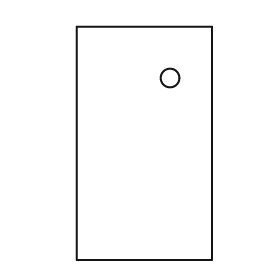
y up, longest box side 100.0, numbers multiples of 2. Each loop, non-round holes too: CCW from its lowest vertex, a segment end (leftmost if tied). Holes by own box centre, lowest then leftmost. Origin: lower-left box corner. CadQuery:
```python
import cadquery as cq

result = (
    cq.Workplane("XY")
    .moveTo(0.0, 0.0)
    .lineTo(58.0, 0.0)
    .lineTo(58.0, 100.0)
    .lineTo(0.0, 100.0)
    .close()
    .moveTo(40.0, 78.0)
    .circle(4.0)
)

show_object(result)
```